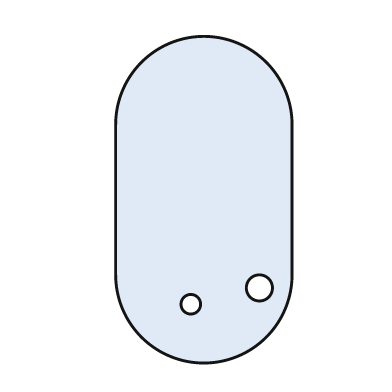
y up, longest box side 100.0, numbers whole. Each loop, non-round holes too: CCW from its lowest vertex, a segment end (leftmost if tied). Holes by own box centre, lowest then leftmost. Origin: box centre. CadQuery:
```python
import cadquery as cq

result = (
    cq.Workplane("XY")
    .moveTo(-27.0, -23.0)
    .threePointArc((0.0, -50.0), (27.0, -23.0))
    .lineTo(27.0, 23.0)
    .threePointArc((0.0, 50.0), (-27.0, 23.0))
    .close()
    .moveTo(-4.0, -32.0)
    .circle(3.0)
    .moveTo(17.0, -27.0)
    .circle(4.0)
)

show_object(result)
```